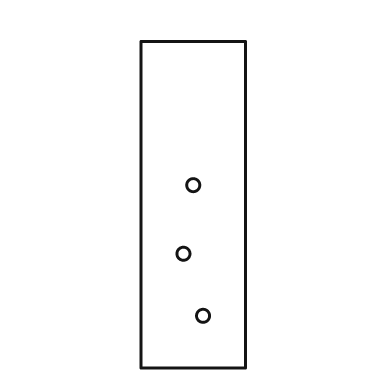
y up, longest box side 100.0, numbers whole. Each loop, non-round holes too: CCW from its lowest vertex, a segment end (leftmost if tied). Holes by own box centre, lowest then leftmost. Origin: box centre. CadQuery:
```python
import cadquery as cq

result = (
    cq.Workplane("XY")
    .moveTo(-16.0, -50.0)
    .lineTo(16.0, -50.0)
    .lineTo(16.0, 50.0)
    .lineTo(-16.0, 50.0)
    .close()
    .moveTo(3.0, -34.0)
    .circle(2.0)
    .moveTo(-3.0, -15.0)
    .circle(2.0)
    .moveTo(0.0, 6.0)
    .circle(2.0)
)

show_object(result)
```